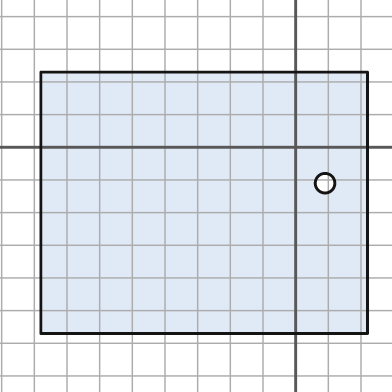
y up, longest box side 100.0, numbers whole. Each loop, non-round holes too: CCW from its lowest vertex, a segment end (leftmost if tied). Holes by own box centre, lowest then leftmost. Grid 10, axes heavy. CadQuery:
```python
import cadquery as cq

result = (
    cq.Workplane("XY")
    .moveTo(-78.0, -57.0)
    .lineTo(22.0, -57.0)
    .lineTo(22.0, 23.0)
    .lineTo(-78.0, 23.0)
    .close()
    .moveTo(9.0, -11.0)
    .circle(3.0)
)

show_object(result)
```